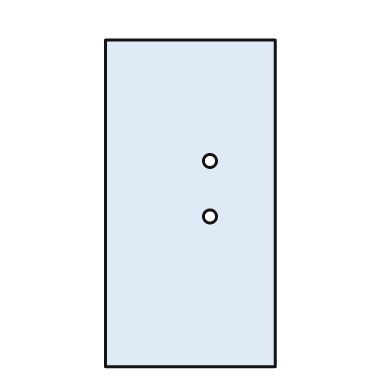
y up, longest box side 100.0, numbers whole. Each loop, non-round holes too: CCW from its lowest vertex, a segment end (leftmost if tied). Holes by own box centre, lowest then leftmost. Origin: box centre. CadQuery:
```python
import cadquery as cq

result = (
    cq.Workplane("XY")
    .moveTo(-26.0, -50.0)
    .lineTo(26.0, -50.0)
    .lineTo(26.0, 50.0)
    .lineTo(-26.0, 50.0)
    .close()
    .moveTo(6.0, -4.0)
    .circle(2.0)
    .moveTo(6.0, 13.0)
    .circle(2.0)
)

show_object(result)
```